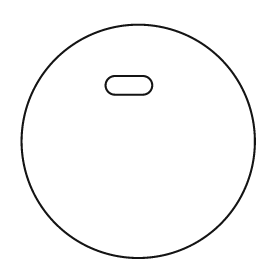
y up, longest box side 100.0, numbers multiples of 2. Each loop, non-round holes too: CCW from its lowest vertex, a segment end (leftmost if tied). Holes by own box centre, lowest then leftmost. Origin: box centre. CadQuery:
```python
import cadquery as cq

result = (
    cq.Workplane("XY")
    .moveTo(0.0, 0.0)
    .circle(50.0)
    .moveTo(-10.0, 20.0)
    .lineTo(2.0, 20.0)
    .threePointArc((6.0, 24.0), (2.0, 28.0))
    .lineTo(-10.0, 28.0)
    .threePointArc((-14.0, 24.0), (-10.0, 20.0))
    .close()
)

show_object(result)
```